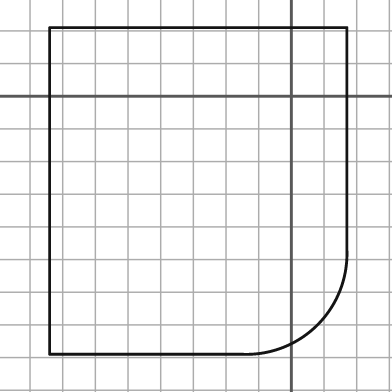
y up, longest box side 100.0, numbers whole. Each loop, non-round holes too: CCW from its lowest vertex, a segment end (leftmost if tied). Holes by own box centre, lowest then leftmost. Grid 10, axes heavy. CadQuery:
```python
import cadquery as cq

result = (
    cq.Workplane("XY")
    .moveTo(-74.0, -79.0)
    .lineTo(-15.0, -79.0)
    .threePointArc((8.0, -70.0), (17.0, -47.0))
    .lineTo(17.0, 21.0)
    .lineTo(-74.0, 21.0)
    .close()
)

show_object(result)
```